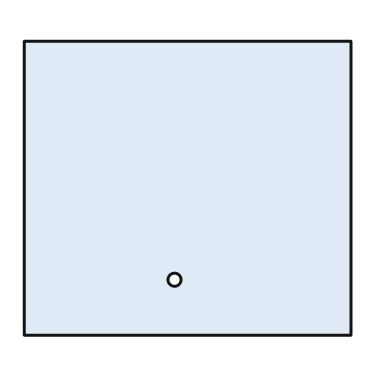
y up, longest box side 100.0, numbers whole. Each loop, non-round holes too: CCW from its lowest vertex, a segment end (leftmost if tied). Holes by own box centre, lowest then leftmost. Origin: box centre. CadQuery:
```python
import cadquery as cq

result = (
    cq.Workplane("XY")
    .moveTo(-50.0, -45.0)
    .lineTo(50.0, -45.0)
    .lineTo(50.0, 45.0)
    .lineTo(-50.0, 45.0)
    .close()
    .moveTo(-4.0, -28.0)
    .circle(2.0)
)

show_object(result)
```